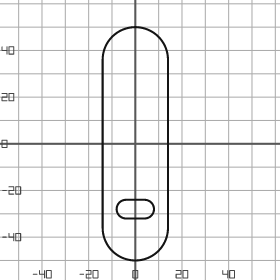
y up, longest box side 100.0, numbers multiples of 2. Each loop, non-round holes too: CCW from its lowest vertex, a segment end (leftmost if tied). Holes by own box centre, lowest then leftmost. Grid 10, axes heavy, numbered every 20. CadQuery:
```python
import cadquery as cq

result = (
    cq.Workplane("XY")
    .moveTo(-14.0, -36.0)
    .threePointArc((0.0, -50.0), (14.0, -36.0))
    .lineTo(14.0, 36.0)
    .threePointArc((0.0, 50.0), (-14.0, 36.0))
    .close()
    .moveTo(-4.0, -32.0)
    .lineTo(4.0, -32.0)
    .threePointArc((8.0, -28.0), (4.0, -24.0))
    .lineTo(-4.0, -24.0)
    .threePointArc((-8.0, -28.0), (-4.0, -32.0))
    .close()
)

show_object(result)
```